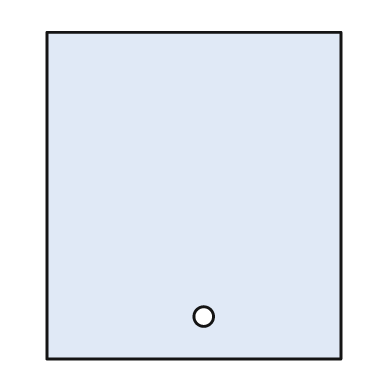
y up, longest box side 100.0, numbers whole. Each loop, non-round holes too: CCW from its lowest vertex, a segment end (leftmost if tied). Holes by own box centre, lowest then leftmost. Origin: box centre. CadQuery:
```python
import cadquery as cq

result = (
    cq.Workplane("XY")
    .moveTo(-45.0, -50.0)
    .lineTo(45.0, -50.0)
    .lineTo(45.0, 50.0)
    .lineTo(-45.0, 50.0)
    .close()
    .moveTo(3.0, -37.0)
    .circle(3.0)
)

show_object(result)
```